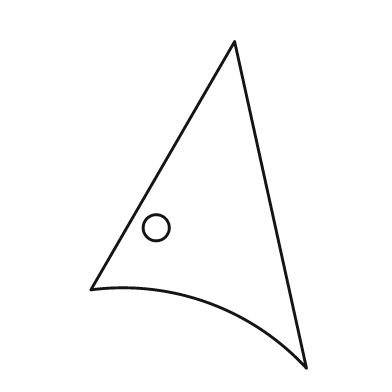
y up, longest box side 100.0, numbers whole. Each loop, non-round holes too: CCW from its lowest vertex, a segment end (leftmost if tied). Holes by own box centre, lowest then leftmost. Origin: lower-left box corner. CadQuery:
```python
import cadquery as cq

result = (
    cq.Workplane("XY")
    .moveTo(66.0, 0.0)
    .lineTo(44.0, 100.0)
    .lineTo(0.0, 24.0)
    .threePointArc((36.0, 20.0), (66.0, 0.0))
    .close()
    .moveTo(20.0, 43.0)
    .circle(4.0)
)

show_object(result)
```